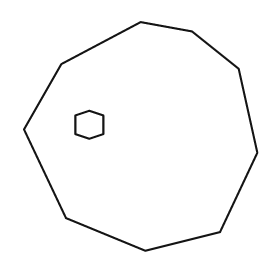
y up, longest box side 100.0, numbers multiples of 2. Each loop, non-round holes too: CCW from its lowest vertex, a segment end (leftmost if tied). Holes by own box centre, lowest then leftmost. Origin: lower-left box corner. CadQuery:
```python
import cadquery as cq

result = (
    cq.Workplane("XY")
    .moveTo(52.0, 0.0)
    .lineTo(84.0, 8.0)
    .lineTo(100.0, 42.0)
    .lineTo(92.0, 78.0)
    .lineTo(72.0, 94.0)
    .lineTo(50.0, 98.0)
    .lineTo(16.0, 80.0)
    .lineTo(0.0, 52.0)
    .lineTo(18.0, 14.0)
    .close()
    .moveTo(28.0, 48.0)
    .lineTo(34.0, 50.0)
    .lineTo(34.0, 58.0)
    .lineTo(28.0, 60.0)
    .lineTo(22.0, 58.0)
    .lineTo(22.0, 50.0)
    .close()
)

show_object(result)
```